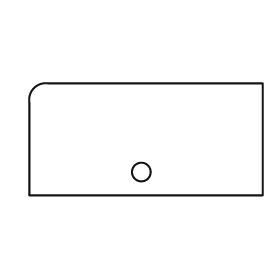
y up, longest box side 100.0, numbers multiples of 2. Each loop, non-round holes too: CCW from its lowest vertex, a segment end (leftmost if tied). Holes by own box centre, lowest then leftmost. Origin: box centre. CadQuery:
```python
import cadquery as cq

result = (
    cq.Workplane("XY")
    .moveTo(-50.0, -24.0)
    .lineTo(50.0, -24.0)
    .lineTo(50.0, 24.0)
    .lineTo(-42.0, 24.0)
    .threePointArc((-48.0, 22.0), (-50.0, 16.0))
    .close()
    .moveTo(-2.0, -14.0)
    .circle(4.0)
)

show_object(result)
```